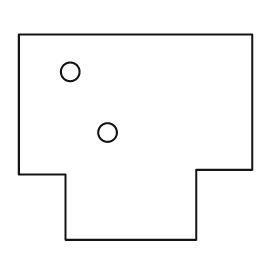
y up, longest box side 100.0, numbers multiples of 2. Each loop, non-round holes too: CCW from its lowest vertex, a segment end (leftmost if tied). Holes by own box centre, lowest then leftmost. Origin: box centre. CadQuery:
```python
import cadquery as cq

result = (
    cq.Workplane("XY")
    .moveTo(-30.0, -44.0)
    .lineTo(26.0, -44.0)
    .lineTo(26.0, -14.0)
    .lineTo(50.0, -14.0)
    .lineTo(50.0, 44.0)
    .lineTo(-50.0, 44.0)
    .lineTo(-50.0, -16.0)
    .lineTo(-30.0, -16.0)
    .close()
    .moveTo(-12.0, 2.0)
    .circle(4.0)
    .moveTo(-28.0, 28.0)
    .circle(4.0)
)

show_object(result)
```